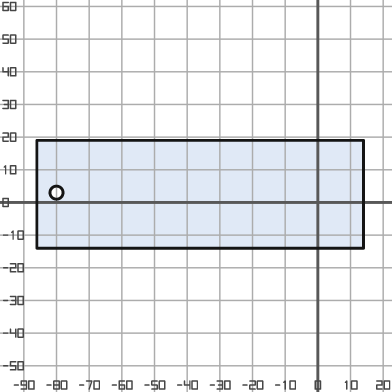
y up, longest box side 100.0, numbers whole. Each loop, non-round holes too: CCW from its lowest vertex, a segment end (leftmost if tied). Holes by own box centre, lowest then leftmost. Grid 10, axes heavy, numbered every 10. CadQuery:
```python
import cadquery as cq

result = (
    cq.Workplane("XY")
    .moveTo(-86.0, -14.0)
    .lineTo(14.0, -14.0)
    .lineTo(14.0, 19.0)
    .lineTo(-86.0, 19.0)
    .close()
    .moveTo(-80.0, 3.0)
    .circle(2.0)
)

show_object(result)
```